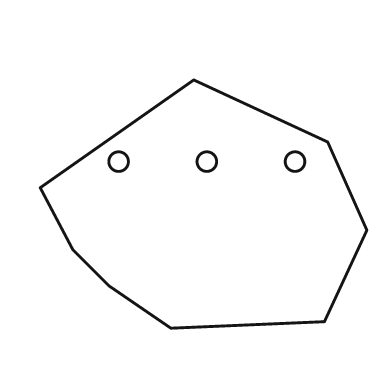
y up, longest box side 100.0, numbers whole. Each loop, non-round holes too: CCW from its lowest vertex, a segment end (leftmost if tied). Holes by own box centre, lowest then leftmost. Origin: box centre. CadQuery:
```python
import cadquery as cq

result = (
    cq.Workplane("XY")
    .moveTo(-10.0, -38.0)
    .lineTo(37.0, -36.0)
    .lineTo(50.0, -8.0)
    .lineTo(38.0, 19.0)
    .lineTo(-3.0, 38.0)
    .lineTo(-50.0, 5.0)
    .lineTo(-40.0, -14.0)
    .lineTo(-29.0, -25.0)
    .close()
    .moveTo(-26.0, 13.0)
    .circle(3.0)
    .moveTo(1.0, 13.0)
    .circle(3.0)
    .moveTo(28.0, 13.0)
    .circle(3.0)
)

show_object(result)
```